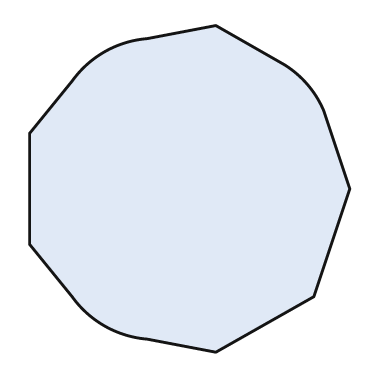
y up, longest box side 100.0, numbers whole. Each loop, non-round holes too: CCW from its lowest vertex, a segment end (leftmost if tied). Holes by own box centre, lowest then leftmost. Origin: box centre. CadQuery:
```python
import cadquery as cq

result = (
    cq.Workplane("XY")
    .moveTo(8.0, -50.0)
    .lineTo(38.0, -33.0)
    .lineTo(49.0, 0.0)
    .lineTo(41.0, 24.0)
    .threePointArc((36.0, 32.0), (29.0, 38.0))
    .lineTo(8.0, 50.0)
    .lineTo(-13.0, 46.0)
    .threePointArc((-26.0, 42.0), (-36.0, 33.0))
    .lineTo(-49.0, 17.0)
    .lineTo(-49.0, -17.0)
    .lineTo(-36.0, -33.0)
    .threePointArc((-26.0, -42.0), (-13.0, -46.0))
    .close()
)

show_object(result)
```